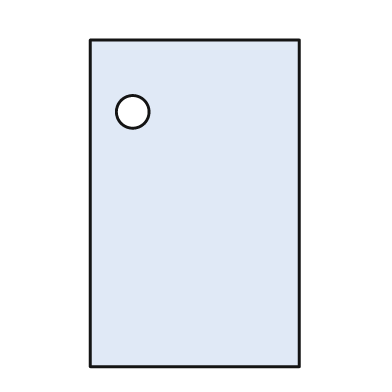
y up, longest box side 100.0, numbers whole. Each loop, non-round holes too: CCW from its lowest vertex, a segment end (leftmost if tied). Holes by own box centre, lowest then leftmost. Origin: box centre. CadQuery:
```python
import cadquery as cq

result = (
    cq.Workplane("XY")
    .moveTo(-32.0, -50.0)
    .lineTo(32.0, -50.0)
    .lineTo(32.0, 50.0)
    .lineTo(-32.0, 50.0)
    .close()
    .moveTo(-19.0, 28.0)
    .circle(5.0)
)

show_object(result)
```